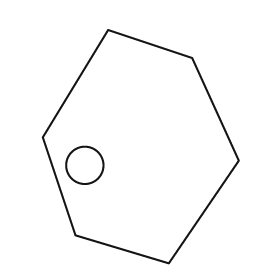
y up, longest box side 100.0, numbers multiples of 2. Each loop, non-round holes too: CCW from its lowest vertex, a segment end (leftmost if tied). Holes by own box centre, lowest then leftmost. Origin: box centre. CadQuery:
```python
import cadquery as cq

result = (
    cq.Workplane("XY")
    .moveTo(12.0, -50.0)
    .lineTo(42.0, -6.0)
    .lineTo(22.0, 38.0)
    .lineTo(-14.0, 50.0)
    .lineTo(-42.0, 4.0)
    .lineTo(-28.0, -38.0)
    .close()
    .moveTo(-24.0, -8.0)
    .circle(8.0)
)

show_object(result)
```